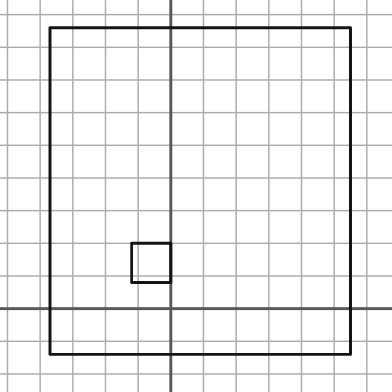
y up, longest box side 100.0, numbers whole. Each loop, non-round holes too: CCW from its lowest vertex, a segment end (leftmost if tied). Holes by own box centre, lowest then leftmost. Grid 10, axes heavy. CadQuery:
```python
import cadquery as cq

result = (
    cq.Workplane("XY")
    .moveTo(-37.0, -14.0)
    .lineTo(55.0, -14.0)
    .lineTo(55.0, 86.0)
    .lineTo(-37.0, 86.0)
    .close()
    .moveTo(-12.0, 8.0)
    .lineTo(0.0, 8.0)
    .lineTo(0.0, 20.0)
    .lineTo(-12.0, 20.0)
    .close()
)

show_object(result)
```